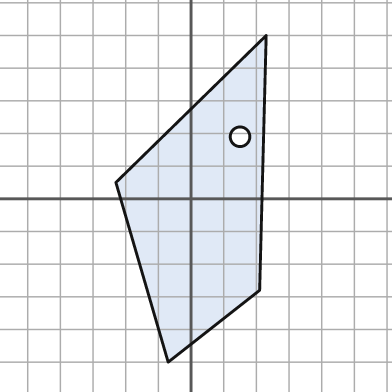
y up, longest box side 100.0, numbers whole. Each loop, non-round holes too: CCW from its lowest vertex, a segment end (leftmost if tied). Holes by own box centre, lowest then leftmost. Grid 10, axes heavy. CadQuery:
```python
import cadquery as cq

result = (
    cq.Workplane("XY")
    .moveTo(-7.0, -50.0)
    .lineTo(21.0, -28.0)
    .lineTo(23.0, 50.0)
    .lineTo(-23.0, 5.0)
    .close()
    .moveTo(15.0, 19.0)
    .circle(3.0)
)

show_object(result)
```